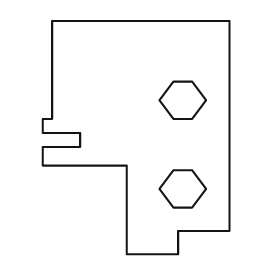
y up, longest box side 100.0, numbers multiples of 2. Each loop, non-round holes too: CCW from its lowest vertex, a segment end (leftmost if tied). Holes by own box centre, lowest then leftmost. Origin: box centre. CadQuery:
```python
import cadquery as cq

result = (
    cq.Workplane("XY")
    .moveTo(-4.0, -50.0)
    .lineTo(18.0, -50.0)
    .lineTo(18.0, -40.0)
    .lineTo(40.0, -40.0)
    .lineTo(40.0, 50.0)
    .lineTo(-36.0, 50.0)
    .lineTo(-36.0, 8.0)
    .lineTo(-40.0, 8.0)
    .lineTo(-40.0, 2.0)
    .lineTo(-24.0, 2.0)
    .lineTo(-24.0, -4.0)
    .lineTo(-40.0, -4.0)
    .lineTo(-40.0, -12.0)
    .lineTo(-4.0, -12.0)
    .close()
    .moveTo(16.0, -30.0)
    .lineTo(24.0, -30.0)
    .lineTo(30.0, -22.0)
    .lineTo(24.0, -14.0)
    .lineTo(16.0, -14.0)
    .lineTo(10.0, -22.0)
    .close()
    .moveTo(16.0, 8.0)
    .lineTo(24.0, 8.0)
    .lineTo(30.0, 16.0)
    .lineTo(24.0, 24.0)
    .lineTo(16.0, 24.0)
    .lineTo(10.0, 16.0)
    .close()
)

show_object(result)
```